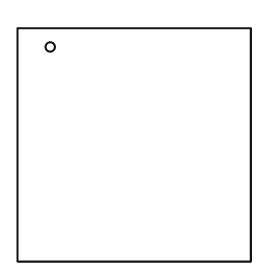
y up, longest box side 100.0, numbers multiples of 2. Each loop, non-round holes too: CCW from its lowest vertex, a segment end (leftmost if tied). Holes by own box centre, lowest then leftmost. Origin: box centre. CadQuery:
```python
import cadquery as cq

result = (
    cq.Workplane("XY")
    .moveTo(-50.0, -50.0)
    .lineTo(50.0, -50.0)
    .lineTo(50.0, 50.0)
    .lineTo(-50.0, 50.0)
    .close()
    .moveTo(-36.0, 42.0)
    .circle(2.0)
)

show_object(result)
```